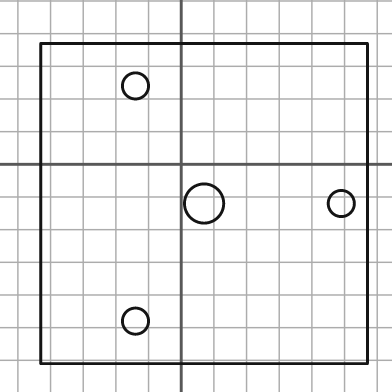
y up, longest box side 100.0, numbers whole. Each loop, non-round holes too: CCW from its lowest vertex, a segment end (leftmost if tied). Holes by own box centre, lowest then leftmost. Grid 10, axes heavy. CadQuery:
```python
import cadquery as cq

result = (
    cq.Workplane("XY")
    .moveTo(-43.0, -61.0)
    .lineTo(57.0, -61.0)
    .lineTo(57.0, 37.0)
    .lineTo(-43.0, 37.0)
    .close()
    .moveTo(-14.0, -48.0)
    .circle(4.0)
    .moveTo(7.0, -12.0)
    .circle(6.0)
    .moveTo(49.0, -12.0)
    .circle(4.0)
    .moveTo(-14.0, 24.0)
    .circle(4.0)
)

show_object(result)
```